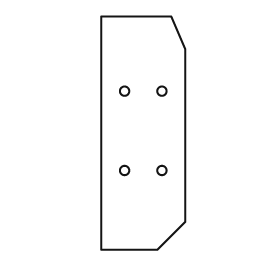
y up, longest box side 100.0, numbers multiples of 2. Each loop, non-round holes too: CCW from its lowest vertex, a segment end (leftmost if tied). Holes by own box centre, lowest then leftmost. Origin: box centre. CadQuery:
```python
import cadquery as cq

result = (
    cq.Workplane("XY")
    .moveTo(-18.0, -50.0)
    .lineTo(6.0, -50.0)
    .lineTo(18.0, -38.0)
    .lineTo(18.0, 36.0)
    .lineTo(12.0, 50.0)
    .lineTo(-18.0, 50.0)
    .close()
    .moveTo(-8.0, -16.0)
    .circle(2.0)
    .moveTo(8.0, -16.0)
    .circle(2.0)
    .moveTo(-8.0, 18.0)
    .circle(2.0)
    .moveTo(8.0, 18.0)
    .circle(2.0)
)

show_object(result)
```